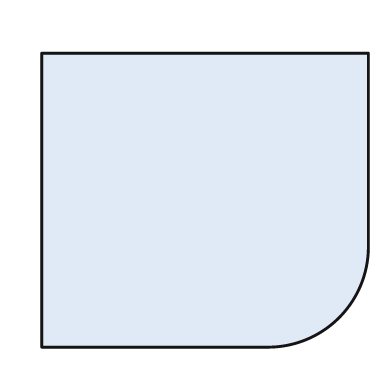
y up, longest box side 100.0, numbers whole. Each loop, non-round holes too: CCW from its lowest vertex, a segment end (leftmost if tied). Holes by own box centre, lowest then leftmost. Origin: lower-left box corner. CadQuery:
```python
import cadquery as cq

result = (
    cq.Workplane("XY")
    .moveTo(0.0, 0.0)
    .lineTo(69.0, 0.0)
    .threePointArc((91.0, 9.0), (100.0, 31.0))
    .lineTo(100.0, 90.0)
    .lineTo(0.0, 90.0)
    .close()
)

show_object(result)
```